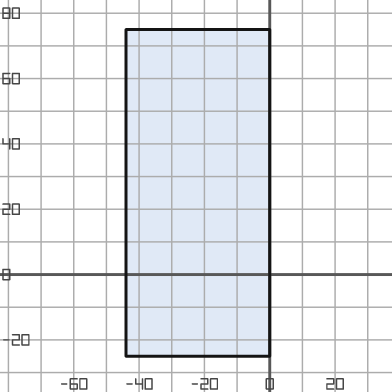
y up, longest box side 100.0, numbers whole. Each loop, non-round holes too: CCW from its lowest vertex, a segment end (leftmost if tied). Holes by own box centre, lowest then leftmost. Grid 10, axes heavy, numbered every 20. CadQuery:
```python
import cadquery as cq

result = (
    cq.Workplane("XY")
    .moveTo(-44.0, -25.0)
    .lineTo(0.0, -25.0)
    .lineTo(0.0, 75.0)
    .lineTo(-44.0, 75.0)
    .close()
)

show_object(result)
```